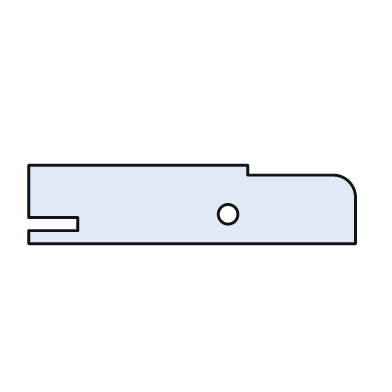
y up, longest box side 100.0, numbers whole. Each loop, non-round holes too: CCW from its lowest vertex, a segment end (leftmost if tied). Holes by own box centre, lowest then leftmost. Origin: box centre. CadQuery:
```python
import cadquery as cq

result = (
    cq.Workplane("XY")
    .moveTo(-50.0, -12.0)
    .lineTo(50.0, -12.0)
    .lineTo(50.0, 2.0)
    .threePointArc((48.0, 7.0), (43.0, 9.0))
    .lineTo(17.0, 9.0)
    .lineTo(17.0, 12.0)
    .lineTo(-50.0, 12.0)
    .lineTo(-50.0, -4.0)
    .lineTo(-35.0, -4.0)
    .lineTo(-35.0, -8.0)
    .lineTo(-50.0, -8.0)
    .close()
    .moveTo(11.0, -3.0)
    .circle(3.0)
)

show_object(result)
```